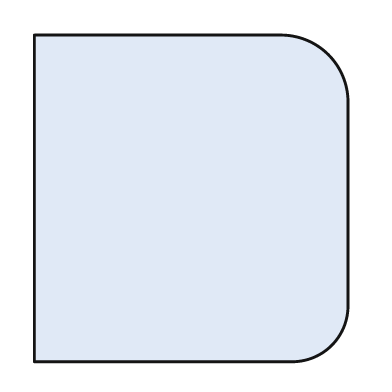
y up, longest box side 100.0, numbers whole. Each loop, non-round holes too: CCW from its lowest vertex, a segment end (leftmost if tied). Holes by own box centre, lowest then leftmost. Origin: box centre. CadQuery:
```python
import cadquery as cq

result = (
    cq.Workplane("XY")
    .moveTo(-48.0, -50.0)
    .lineTo(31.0, -50.0)
    .threePointArc((43.0, -45.0), (48.0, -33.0))
    .lineTo(48.0, 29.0)
    .threePointArc((42.0, 44.0), (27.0, 50.0))
    .lineTo(-48.0, 50.0)
    .close()
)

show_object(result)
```